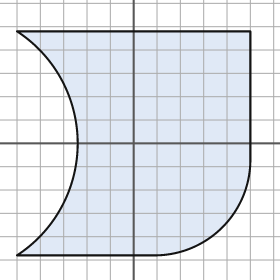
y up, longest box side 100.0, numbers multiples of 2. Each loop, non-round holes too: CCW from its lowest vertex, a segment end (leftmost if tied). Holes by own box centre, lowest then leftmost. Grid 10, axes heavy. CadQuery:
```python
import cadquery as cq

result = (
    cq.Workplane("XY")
    .moveTo(-50.0, -48.0)
    .lineTo(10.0, -48.0)
    .threePointArc((38.0, -36.0), (50.0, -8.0))
    .lineTo(50.0, 48.0)
    .lineTo(-50.0, 48.0)
    .threePointArc((-24.0, 0.0), (-50.0, -48.0))
    .close()
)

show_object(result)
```